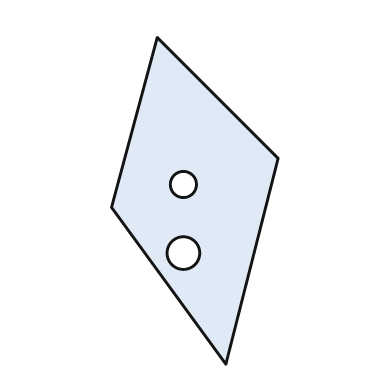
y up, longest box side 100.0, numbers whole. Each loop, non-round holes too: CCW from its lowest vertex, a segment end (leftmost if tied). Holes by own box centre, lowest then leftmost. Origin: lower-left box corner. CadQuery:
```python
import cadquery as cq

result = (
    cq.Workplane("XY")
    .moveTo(35.0, 0.0)
    .lineTo(51.0, 63.0)
    .lineTo(14.0, 100.0)
    .lineTo(0.0, 48.0)
    .close()
    .moveTo(22.0, 34.0)
    .circle(5.0)
    .moveTo(22.0, 55.0)
    .circle(4.0)
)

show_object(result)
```